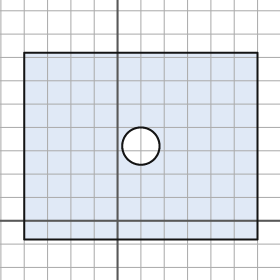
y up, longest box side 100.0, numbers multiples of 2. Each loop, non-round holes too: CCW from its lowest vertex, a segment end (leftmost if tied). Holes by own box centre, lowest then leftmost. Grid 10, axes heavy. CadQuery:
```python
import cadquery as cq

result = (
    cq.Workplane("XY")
    .moveTo(-40.0, -8.0)
    .lineTo(60.0, -8.0)
    .lineTo(60.0, 72.0)
    .lineTo(-40.0, 72.0)
    .close()
    .moveTo(10.0, 32.0)
    .circle(8.0)
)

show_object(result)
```